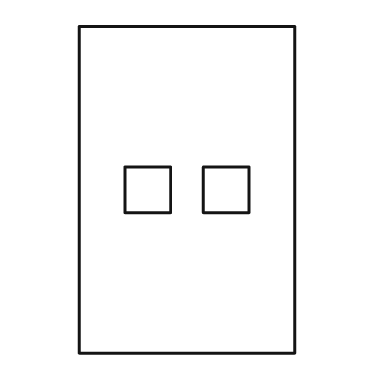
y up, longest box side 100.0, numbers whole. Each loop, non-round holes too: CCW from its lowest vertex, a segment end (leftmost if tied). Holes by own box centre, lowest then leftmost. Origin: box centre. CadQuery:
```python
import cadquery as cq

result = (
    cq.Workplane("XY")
    .moveTo(-33.0, -50.0)
    .lineTo(33.0, -50.0)
    .lineTo(33.0, 50.0)
    .lineTo(-33.0, 50.0)
    .close()
    .moveTo(-19.0, -7.0)
    .lineTo(-5.0, -7.0)
    .lineTo(-5.0, 7.0)
    .lineTo(-19.0, 7.0)
    .close()
    .moveTo(5.0, -7.0)
    .lineTo(19.0, -7.0)
    .lineTo(19.0, 7.0)
    .lineTo(5.0, 7.0)
    .close()
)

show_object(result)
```